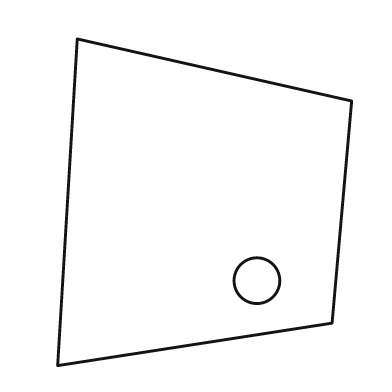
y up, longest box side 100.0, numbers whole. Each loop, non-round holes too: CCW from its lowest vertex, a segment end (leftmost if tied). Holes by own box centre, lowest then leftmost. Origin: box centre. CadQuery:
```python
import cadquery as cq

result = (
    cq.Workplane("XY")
    .moveTo(-45.0, -50.0)
    .lineTo(39.0, -37.0)
    .lineTo(45.0, 31.0)
    .lineTo(-39.0, 50.0)
    .close()
    .moveTo(16.0, -24.0)
    .circle(7.0)
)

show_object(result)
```